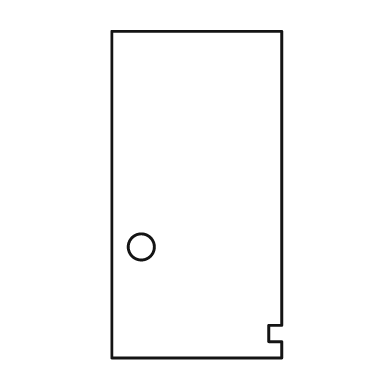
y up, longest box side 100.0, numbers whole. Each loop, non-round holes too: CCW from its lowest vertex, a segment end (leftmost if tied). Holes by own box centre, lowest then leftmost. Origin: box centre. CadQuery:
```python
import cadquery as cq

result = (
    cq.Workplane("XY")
    .moveTo(-26.0, -50.0)
    .lineTo(26.0, -50.0)
    .lineTo(26.0, -45.0)
    .lineTo(22.0, -45.0)
    .lineTo(22.0, -40.0)
    .lineTo(26.0, -40.0)
    .lineTo(26.0, 50.0)
    .lineTo(-26.0, 50.0)
    .close()
    .moveTo(-17.0, -16.0)
    .circle(4.0)
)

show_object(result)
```